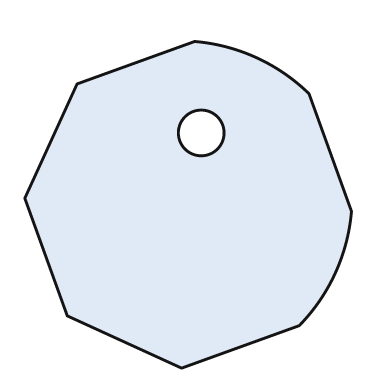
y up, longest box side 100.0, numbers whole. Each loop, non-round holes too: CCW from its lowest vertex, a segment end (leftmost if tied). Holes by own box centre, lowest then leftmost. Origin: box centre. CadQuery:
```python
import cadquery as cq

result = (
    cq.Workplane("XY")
    .moveTo(-2.0, -50.0)
    .lineTo(34.0, -37.0)
    .threePointArc((45.0, -21.0), (50.0, -2.0))
    .lineTo(37.0, 34.0)
    .threePointArc((21.0, 45.0), (2.0, 50.0))
    .lineTo(-34.0, 37.0)
    .lineTo(-50.0, 2.0)
    .lineTo(-37.0, -34.0)
    .close()
    .moveTo(4.0, 22.0)
    .circle(7.0)
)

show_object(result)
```